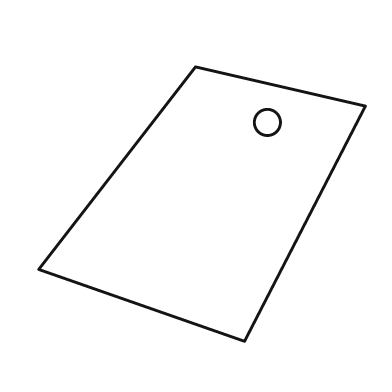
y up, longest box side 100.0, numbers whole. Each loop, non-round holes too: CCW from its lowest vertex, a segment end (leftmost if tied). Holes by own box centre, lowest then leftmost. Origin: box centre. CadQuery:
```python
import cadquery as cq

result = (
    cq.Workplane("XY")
    .moveTo(13.0, -42.0)
    .lineTo(50.0, 30.0)
    .lineTo(-2.0, 42.0)
    .lineTo(-50.0, -20.0)
    .close()
    .moveTo(20.0, 25.0)
    .circle(4.0)
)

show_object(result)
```